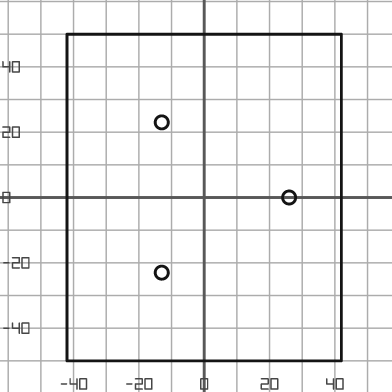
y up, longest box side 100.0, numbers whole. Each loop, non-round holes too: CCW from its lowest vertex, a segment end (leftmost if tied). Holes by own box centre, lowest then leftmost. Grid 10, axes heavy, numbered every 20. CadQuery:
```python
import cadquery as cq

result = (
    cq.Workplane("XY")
    .moveTo(-42.0, -50.0)
    .lineTo(42.0, -50.0)
    .lineTo(42.0, 50.0)
    .lineTo(-42.0, 50.0)
    .close()
    .moveTo(-13.0, -23.0)
    .circle(2.0)
    .moveTo(26.0, 0.0)
    .circle(2.0)
    .moveTo(-13.0, 23.0)
    .circle(2.0)
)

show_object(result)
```